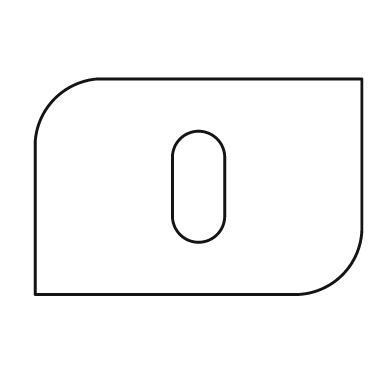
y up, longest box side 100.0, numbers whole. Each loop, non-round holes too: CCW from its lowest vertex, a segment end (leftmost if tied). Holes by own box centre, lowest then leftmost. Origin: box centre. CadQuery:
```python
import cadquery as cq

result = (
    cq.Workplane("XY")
    .moveTo(-50.0, -33.0)
    .lineTo(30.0, -33.0)
    .threePointArc((44.0, -27.0), (50.0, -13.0))
    .lineTo(50.0, 33.0)
    .lineTo(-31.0, 33.0)
    .threePointArc((-44.0, 27.0), (-50.0, 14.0))
    .close()
    .moveTo(-8.0, -9.0)
    .threePointArc((0.0, -17.0), (8.0, -9.0))
    .lineTo(8.0, 9.0)
    .threePointArc((0.0, 17.0), (-8.0, 9.0))
    .close()
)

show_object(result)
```